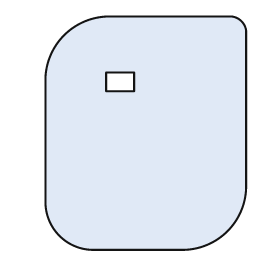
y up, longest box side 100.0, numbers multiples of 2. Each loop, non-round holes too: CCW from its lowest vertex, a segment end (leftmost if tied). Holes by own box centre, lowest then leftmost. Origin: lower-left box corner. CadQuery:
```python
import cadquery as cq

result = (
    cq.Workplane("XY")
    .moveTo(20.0, 0.0)
    .lineTo(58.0, 0.0)
    .threePointArc((78.0, 8.0), (86.0, 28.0))
    .lineTo(86.0, 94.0)
    .threePointArc((84.0, 98.0), (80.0, 100.0))
    .lineTo(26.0, 100.0)
    .threePointArc((8.0, 92.0), (0.0, 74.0))
    .lineTo(0.0, 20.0)
    .threePointArc((6.0, 6.0), (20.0, 0.0))
    .close()
    .moveTo(26.0, 68.0)
    .lineTo(38.0, 68.0)
    .lineTo(38.0, 76.0)
    .lineTo(26.0, 76.0)
    .close()
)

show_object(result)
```